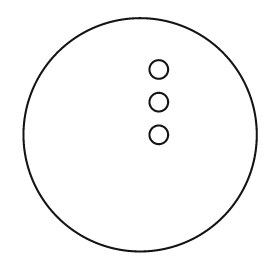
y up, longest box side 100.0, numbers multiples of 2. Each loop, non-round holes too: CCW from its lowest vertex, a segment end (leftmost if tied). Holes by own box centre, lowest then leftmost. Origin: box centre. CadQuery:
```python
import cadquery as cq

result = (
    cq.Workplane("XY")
    .moveTo(0.0, 0.0)
    .circle(50.0)
    .moveTo(8.0, 0.0)
    .circle(4.0)
    .moveTo(8.0, 14.0)
    .circle(4.0)
    .moveTo(8.0, 28.0)
    .circle(4.0)
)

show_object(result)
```